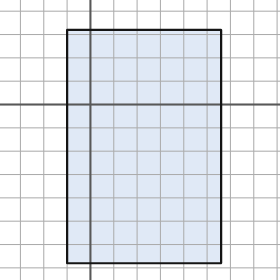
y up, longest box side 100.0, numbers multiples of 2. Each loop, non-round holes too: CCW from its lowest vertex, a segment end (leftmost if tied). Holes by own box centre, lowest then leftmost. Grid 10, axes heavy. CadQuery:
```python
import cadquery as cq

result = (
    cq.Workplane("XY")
    .moveTo(-10.0, -68.0)
    .lineTo(56.0, -68.0)
    .lineTo(56.0, 32.0)
    .lineTo(-10.0, 32.0)
    .close()
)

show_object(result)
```